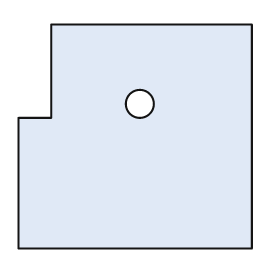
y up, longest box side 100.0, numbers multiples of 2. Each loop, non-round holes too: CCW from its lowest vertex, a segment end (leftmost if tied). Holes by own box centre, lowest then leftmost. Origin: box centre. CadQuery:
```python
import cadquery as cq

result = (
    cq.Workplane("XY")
    .moveTo(-50.0, -48.0)
    .lineTo(50.0, -48.0)
    .lineTo(50.0, 48.0)
    .lineTo(-36.0, 48.0)
    .lineTo(-36.0, 8.0)
    .lineTo(-50.0, 8.0)
    .close()
    .moveTo(2.0, 14.0)
    .circle(6.0)
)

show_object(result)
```